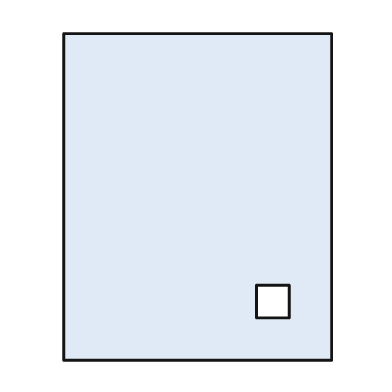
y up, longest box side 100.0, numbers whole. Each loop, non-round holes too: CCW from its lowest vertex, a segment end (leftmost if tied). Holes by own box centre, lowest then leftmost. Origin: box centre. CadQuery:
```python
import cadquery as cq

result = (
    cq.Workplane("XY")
    .moveTo(-41.0, -50.0)
    .lineTo(41.0, -50.0)
    .lineTo(41.0, 50.0)
    .lineTo(-41.0, 50.0)
    .close()
    .moveTo(18.0, -37.0)
    .lineTo(28.0, -37.0)
    .lineTo(28.0, -27.0)
    .lineTo(18.0, -27.0)
    .close()
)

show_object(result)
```